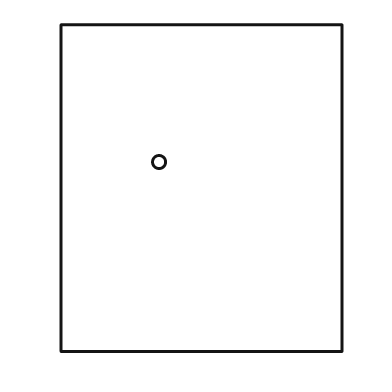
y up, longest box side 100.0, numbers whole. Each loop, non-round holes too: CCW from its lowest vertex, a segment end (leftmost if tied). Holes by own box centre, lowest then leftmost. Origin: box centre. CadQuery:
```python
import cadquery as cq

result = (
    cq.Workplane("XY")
    .moveTo(-43.0, -50.0)
    .lineTo(43.0, -50.0)
    .lineTo(43.0, 50.0)
    .lineTo(-43.0, 50.0)
    .close()
    .moveTo(-13.0, 8.0)
    .circle(2.0)
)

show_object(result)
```